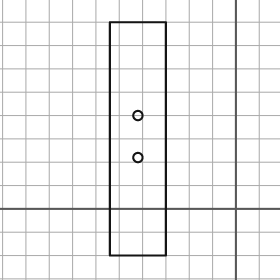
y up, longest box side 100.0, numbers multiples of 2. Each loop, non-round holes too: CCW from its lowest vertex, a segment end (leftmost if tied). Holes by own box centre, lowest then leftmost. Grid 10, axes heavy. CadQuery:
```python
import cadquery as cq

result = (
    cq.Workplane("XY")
    .moveTo(-54.0, -20.0)
    .lineTo(-30.0, -20.0)
    .lineTo(-30.0, 80.0)
    .lineTo(-54.0, 80.0)
    .close()
    .moveTo(-42.0, 22.0)
    .circle(2.0)
    .moveTo(-42.0, 40.0)
    .circle(2.0)
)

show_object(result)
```